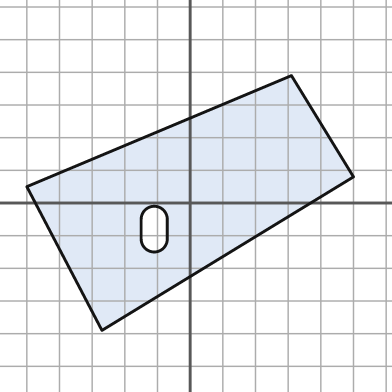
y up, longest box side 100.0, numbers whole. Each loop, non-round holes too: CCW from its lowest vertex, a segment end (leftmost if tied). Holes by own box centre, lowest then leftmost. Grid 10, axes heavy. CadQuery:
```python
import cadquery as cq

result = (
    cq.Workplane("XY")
    .moveTo(-27.0, -39.0)
    .lineTo(50.0, 8.0)
    .lineTo(31.0, 39.0)
    .lineTo(-50.0, 5.0)
    .close()
    .moveTo(-15.0, -11.0)
    .threePointArc((-11.0, -15.0), (-7.0, -11.0))
    .lineTo(-7.0, -5.0)
    .threePointArc((-11.0, -1.0), (-15.0, -5.0))
    .close()
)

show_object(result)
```